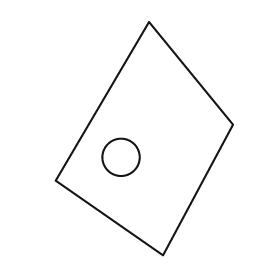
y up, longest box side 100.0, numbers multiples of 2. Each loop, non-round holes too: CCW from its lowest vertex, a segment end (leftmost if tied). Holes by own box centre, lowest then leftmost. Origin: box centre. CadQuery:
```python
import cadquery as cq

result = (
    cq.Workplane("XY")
    .moveTo(8.0, -50.0)
    .lineTo(38.0, 6.0)
    .lineTo(2.0, 50.0)
    .lineTo(-38.0, -18.0)
    .close()
    .moveTo(-10.0, -8.0)
    .circle(8.0)
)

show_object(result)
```